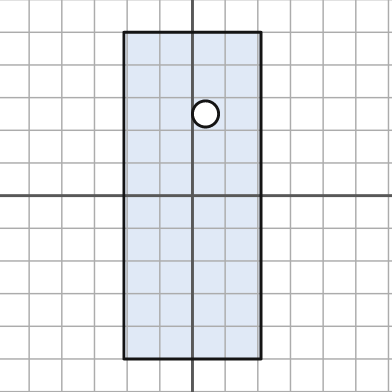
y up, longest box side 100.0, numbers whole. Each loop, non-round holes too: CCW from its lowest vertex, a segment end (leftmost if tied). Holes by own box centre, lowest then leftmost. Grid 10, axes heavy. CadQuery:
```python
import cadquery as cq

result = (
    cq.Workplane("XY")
    .moveTo(-21.0, -50.0)
    .lineTo(21.0, -50.0)
    .lineTo(21.0, 50.0)
    .lineTo(-21.0, 50.0)
    .close()
    .moveTo(4.0, 25.0)
    .circle(4.0)
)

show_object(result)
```